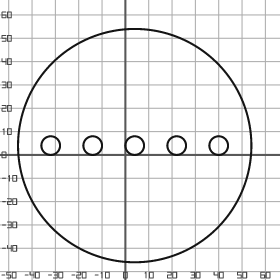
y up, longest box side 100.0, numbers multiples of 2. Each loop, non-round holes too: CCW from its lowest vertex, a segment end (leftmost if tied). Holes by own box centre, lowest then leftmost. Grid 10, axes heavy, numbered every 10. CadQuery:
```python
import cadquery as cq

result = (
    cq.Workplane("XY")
    .moveTo(4.0, 4.0)
    .circle(50.0)
    .moveTo(-32.0, 4.0)
    .circle(4.0)
    .moveTo(-14.0, 4.0)
    .circle(4.0)
    .moveTo(4.0, 4.0)
    .circle(4.0)
    .moveTo(22.0, 4.0)
    .circle(4.0)
    .moveTo(40.0, 4.0)
    .circle(4.0)
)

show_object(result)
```